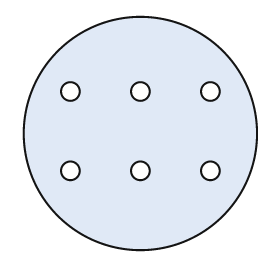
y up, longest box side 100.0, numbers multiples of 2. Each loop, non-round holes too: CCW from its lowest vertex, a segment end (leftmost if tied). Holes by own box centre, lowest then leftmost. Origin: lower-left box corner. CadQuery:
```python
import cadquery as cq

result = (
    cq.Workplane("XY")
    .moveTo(50.0, 50.0)
    .circle(50.0)
    .moveTo(20.0, 34.0)
    .circle(4.0)
    .moveTo(50.0, 34.0)
    .circle(4.0)
    .moveTo(80.0, 34.0)
    .circle(4.0)
    .moveTo(20.0, 68.0)
    .circle(4.0)
    .moveTo(50.0, 68.0)
    .circle(4.0)
    .moveTo(80.0, 68.0)
    .circle(4.0)
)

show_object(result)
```